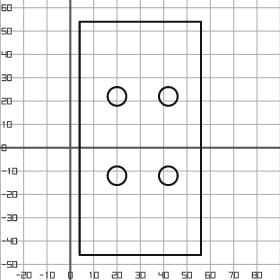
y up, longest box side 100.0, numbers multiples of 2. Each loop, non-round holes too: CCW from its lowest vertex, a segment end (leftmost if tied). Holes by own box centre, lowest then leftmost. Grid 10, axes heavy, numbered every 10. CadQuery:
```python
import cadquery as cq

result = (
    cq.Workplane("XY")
    .moveTo(4.0, -46.0)
    .lineTo(56.0, -46.0)
    .lineTo(56.0, 54.0)
    .lineTo(4.0, 54.0)
    .close()
    .moveTo(20.0, -12.0)
    .circle(4.0)
    .moveTo(42.0, -12.0)
    .circle(4.0)
    .moveTo(20.0, 22.0)
    .circle(4.0)
    .moveTo(42.0, 22.0)
    .circle(4.0)
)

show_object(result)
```